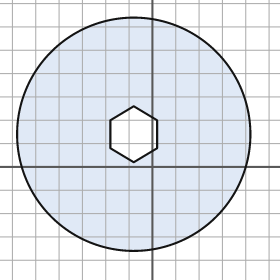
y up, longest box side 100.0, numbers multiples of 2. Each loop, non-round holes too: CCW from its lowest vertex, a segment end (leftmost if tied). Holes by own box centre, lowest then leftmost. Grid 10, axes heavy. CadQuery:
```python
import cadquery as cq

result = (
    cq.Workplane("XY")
    .moveTo(-8.0, 14.0)
    .circle(50.0)
    .moveTo(-8.0, 2.0)
    .lineTo(2.0, 8.0)
    .lineTo(2.0, 20.0)
    .lineTo(-8.0, 26.0)
    .lineTo(-18.0, 20.0)
    .lineTo(-18.0, 8.0)
    .close()
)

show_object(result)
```